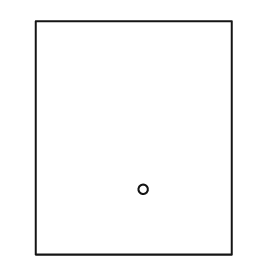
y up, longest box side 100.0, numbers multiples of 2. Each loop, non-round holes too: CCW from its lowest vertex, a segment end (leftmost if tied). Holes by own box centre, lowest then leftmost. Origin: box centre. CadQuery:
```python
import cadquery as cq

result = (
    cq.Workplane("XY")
    .moveTo(-42.0, -50.0)
    .lineTo(42.0, -50.0)
    .lineTo(42.0, 50.0)
    .lineTo(-42.0, 50.0)
    .close()
    .moveTo(4.0, -22.0)
    .circle(2.0)
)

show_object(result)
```